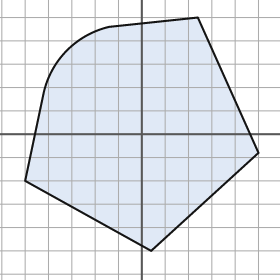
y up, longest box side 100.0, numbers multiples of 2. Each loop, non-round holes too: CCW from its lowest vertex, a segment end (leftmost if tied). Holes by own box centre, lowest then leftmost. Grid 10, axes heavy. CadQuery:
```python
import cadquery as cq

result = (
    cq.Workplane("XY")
    .moveTo(4.0, -50.0)
    .lineTo(50.0, -8.0)
    .lineTo(24.0, 50.0)
    .lineTo(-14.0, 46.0)
    .threePointArc((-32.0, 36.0), (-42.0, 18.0))
    .lineTo(-50.0, -20.0)
    .close()
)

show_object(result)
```